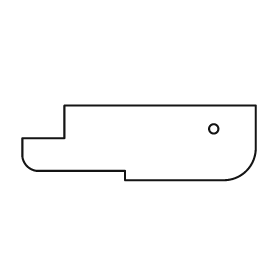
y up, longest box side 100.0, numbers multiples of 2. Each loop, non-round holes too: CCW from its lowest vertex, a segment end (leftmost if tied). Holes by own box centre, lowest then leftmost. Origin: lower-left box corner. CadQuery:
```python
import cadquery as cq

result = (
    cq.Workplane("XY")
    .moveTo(44.0, 0.0)
    .lineTo(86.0, 0.0)
    .threePointArc((96.0, 4.0), (100.0, 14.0))
    .lineTo(100.0, 32.0)
    .lineTo(18.0, 32.0)
    .lineTo(18.0, 18.0)
    .lineTo(0.0, 18.0)
    .lineTo(0.0, 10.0)
    .threePointArc((2.0, 6.0), (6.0, 4.0))
    .lineTo(44.0, 4.0)
    .close()
    .moveTo(82.0, 22.0)
    .circle(2.0)
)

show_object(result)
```